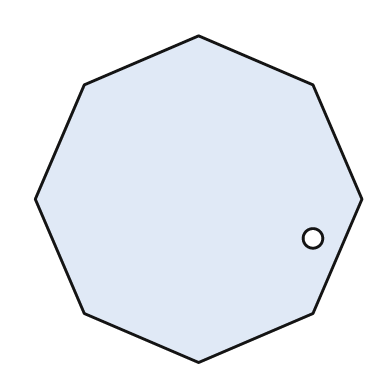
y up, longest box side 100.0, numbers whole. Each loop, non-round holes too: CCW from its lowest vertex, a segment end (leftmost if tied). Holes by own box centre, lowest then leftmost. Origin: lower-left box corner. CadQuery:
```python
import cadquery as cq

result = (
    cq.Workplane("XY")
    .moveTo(50.0, 0.0)
    .lineTo(85.0, 15.0)
    .lineTo(100.0, 50.0)
    .lineTo(85.0, 85.0)
    .lineTo(50.0, 100.0)
    .lineTo(15.0, 85.0)
    .lineTo(0.0, 50.0)
    .lineTo(15.0, 15.0)
    .close()
    .moveTo(85.0, 38.0)
    .circle(3.0)
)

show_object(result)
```